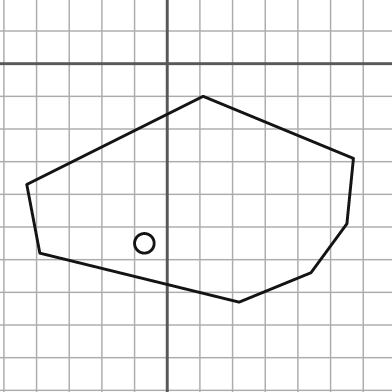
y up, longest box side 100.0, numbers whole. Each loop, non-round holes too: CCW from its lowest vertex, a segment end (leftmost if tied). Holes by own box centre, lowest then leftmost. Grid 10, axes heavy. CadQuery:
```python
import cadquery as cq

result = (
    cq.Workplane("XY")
    .moveTo(22.0, -73.0)
    .lineTo(44.0, -64.0)
    .lineTo(55.0, -49.0)
    .lineTo(57.0, -29.0)
    .lineTo(11.0, -10.0)
    .lineTo(-43.0, -37.0)
    .lineTo(-39.0, -58.0)
    .close()
    .moveTo(-7.0, -55.0)
    .circle(3.0)
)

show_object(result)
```